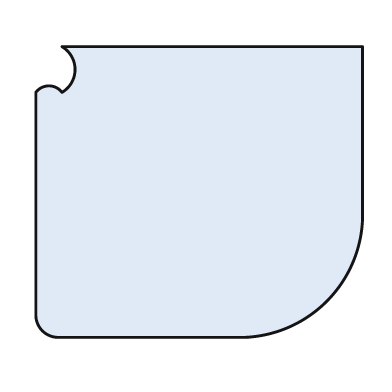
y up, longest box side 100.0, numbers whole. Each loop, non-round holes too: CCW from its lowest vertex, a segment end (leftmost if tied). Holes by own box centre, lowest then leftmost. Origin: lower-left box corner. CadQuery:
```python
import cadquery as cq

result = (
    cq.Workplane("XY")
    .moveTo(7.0, 0.0)
    .lineTo(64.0, 0.0)
    .threePointArc((89.0, 11.0), (100.0, 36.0))
    .lineTo(100.0, 89.0)
    .lineTo(8.0, 89.0)
    .threePointArc((12.0, 82.0), (8.0, 75.0))
    .threePointArc((4.0, 77.0), (0.0, 75.0))
    .lineTo(0.0, 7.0)
    .threePointArc((2.0, 2.0), (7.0, 0.0))
    .close()
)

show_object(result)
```